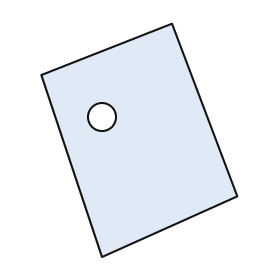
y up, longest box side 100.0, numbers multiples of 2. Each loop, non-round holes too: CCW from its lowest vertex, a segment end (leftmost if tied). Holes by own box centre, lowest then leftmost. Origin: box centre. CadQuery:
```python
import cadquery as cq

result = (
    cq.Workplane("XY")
    .moveTo(-16.0, -50.0)
    .lineTo(42.0, -24.0)
    .lineTo(14.0, 50.0)
    .lineTo(-42.0, 28.0)
    .close()
    .moveTo(-16.0, 10.0)
    .circle(6.0)
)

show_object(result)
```